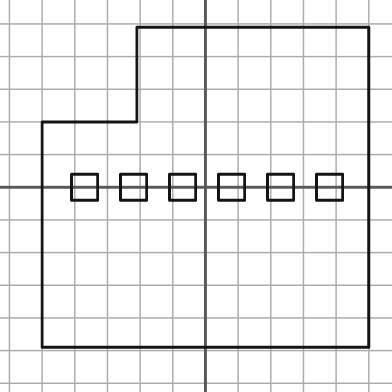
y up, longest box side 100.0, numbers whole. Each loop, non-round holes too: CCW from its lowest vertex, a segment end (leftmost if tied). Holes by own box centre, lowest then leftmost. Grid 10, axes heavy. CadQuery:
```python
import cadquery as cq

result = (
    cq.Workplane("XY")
    .moveTo(-50.0, -49.0)
    .lineTo(50.0, -49.0)
    .lineTo(50.0, 49.0)
    .lineTo(-21.0, 49.0)
    .lineTo(-21.0, 20.0)
    .lineTo(-50.0, 20.0)
    .close()
    .moveTo(-41.0, -4.0)
    .lineTo(-33.0, -4.0)
    .lineTo(-33.0, 4.0)
    .lineTo(-41.0, 4.0)
    .close()
    .moveTo(-26.0, -4.0)
    .lineTo(-18.0, -4.0)
    .lineTo(-18.0, 4.0)
    .lineTo(-26.0, 4.0)
    .close()
    .moveTo(-11.0, -4.0)
    .lineTo(-3.0, -4.0)
    .lineTo(-3.0, 4.0)
    .lineTo(-11.0, 4.0)
    .close()
    .moveTo(4.0, -4.0)
    .lineTo(12.0, -4.0)
    .lineTo(12.0, 4.0)
    .lineTo(4.0, 4.0)
    .close()
    .moveTo(19.0, -4.0)
    .lineTo(27.0, -4.0)
    .lineTo(27.0, 4.0)
    .lineTo(19.0, 4.0)
    .close()
    .moveTo(34.0, -4.0)
    .lineTo(42.0, -4.0)
    .lineTo(42.0, 4.0)
    .lineTo(34.0, 4.0)
    .close()
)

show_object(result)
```